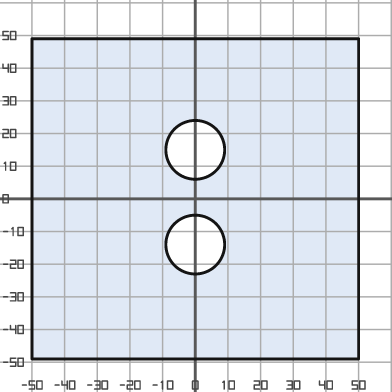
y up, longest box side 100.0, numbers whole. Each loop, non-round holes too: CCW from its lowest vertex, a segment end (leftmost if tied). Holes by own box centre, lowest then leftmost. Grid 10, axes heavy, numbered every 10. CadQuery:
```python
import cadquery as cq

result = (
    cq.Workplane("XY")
    .moveTo(-50.0, -49.0)
    .lineTo(50.0, -49.0)
    .lineTo(50.0, 49.0)
    .lineTo(-50.0, 49.0)
    .close()
    .moveTo(0.0, -14.0)
    .circle(9.0)
    .moveTo(0.0, 15.0)
    .circle(9.0)
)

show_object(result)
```